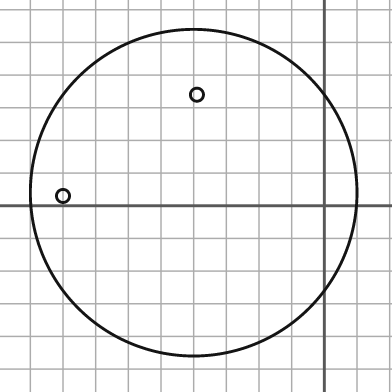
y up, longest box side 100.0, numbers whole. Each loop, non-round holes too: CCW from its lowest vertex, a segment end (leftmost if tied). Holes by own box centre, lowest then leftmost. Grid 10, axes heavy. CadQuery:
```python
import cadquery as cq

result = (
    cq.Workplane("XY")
    .moveTo(-40.0, 4.0)
    .circle(50.0)
    .moveTo(-80.0, 3.0)
    .circle(2.0)
    .moveTo(-39.0, 34.0)
    .circle(2.0)
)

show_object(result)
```